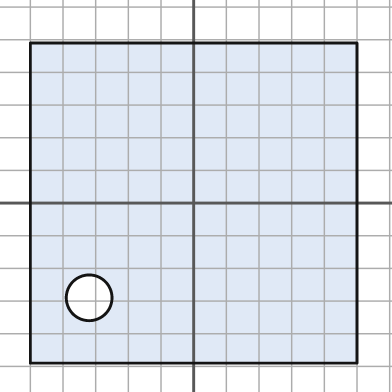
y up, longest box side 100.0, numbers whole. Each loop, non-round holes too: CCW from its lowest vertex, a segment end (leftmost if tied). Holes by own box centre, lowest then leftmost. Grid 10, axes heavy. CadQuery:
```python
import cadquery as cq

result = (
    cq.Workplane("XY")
    .moveTo(-50.0, -49.0)
    .lineTo(50.0, -49.0)
    .lineTo(50.0, 49.0)
    .lineTo(-50.0, 49.0)
    .close()
    .moveTo(-32.0, -29.0)
    .circle(7.0)
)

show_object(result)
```